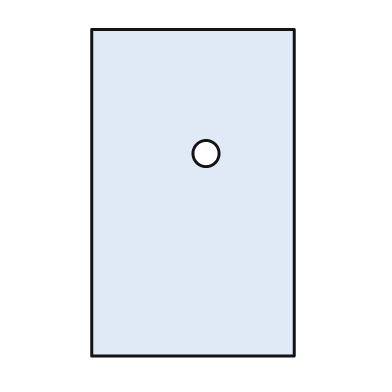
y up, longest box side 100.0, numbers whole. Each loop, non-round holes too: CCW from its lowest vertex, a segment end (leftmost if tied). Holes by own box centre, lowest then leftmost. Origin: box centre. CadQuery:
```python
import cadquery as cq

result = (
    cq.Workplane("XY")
    .moveTo(-31.0, -50.0)
    .lineTo(31.0, -50.0)
    .lineTo(31.0, 50.0)
    .lineTo(-31.0, 50.0)
    .close()
    .moveTo(4.0, 12.0)
    .circle(4.0)
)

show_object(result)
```